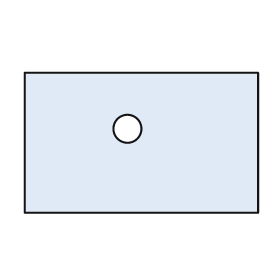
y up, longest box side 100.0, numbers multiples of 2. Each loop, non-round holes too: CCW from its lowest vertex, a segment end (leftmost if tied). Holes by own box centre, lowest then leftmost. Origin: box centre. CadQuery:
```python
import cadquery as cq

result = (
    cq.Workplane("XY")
    .moveTo(-50.0, -30.0)
    .lineTo(50.0, -30.0)
    .lineTo(50.0, 30.0)
    .lineTo(-50.0, 30.0)
    .close()
    .moveTo(-6.0, 6.0)
    .circle(6.0)
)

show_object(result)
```